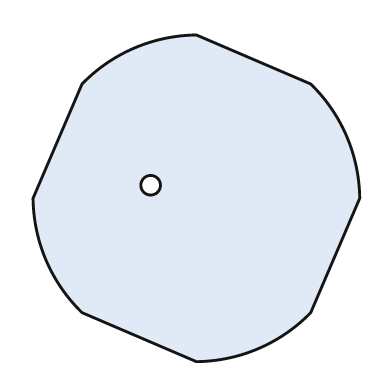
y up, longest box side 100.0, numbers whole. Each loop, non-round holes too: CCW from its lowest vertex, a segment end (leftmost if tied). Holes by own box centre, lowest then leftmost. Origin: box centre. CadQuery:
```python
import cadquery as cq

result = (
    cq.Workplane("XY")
    .moveTo(0.0, -50.0)
    .threePointArc((19.0, -46.0), (35.0, -35.0))
    .lineTo(50.0, 0.0)
    .threePointArc((46.0, 19.0), (35.0, 35.0))
    .lineTo(0.0, 50.0)
    .threePointArc((-19.0, 46.0), (-35.0, 35.0))
    .lineTo(-50.0, 0.0)
    .threePointArc((-46.0, -19.0), (-35.0, -35.0))
    .close()
    .moveTo(-14.0, 4.0)
    .circle(3.0)
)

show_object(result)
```